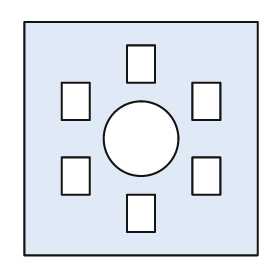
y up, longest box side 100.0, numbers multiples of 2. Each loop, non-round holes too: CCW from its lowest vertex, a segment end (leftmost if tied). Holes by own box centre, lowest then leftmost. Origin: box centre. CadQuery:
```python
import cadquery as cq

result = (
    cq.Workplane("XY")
    .moveTo(-50.0, -50.0)
    .lineTo(50.0, -50.0)
    .lineTo(50.0, 50.0)
    .lineTo(-50.0, 50.0)
    .close()
    .moveTo(-6.0, -40.0)
    .lineTo(6.0, -40.0)
    .lineTo(6.0, -24.0)
    .lineTo(-6.0, -24.0)
    .close()
    .moveTo(-34.0, -24.0)
    .lineTo(-22.0, -24.0)
    .lineTo(-22.0, -8.0)
    .lineTo(-34.0, -8.0)
    .close()
    .moveTo(22.0, -24.0)
    .lineTo(34.0, -24.0)
    .lineTo(34.0, -8.0)
    .lineTo(22.0, -8.0)
    .close()
    .moveTo(0.0, 0.0)
    .circle(16.0)
    .moveTo(-34.0, 8.0)
    .lineTo(-22.0, 8.0)
    .lineTo(-22.0, 24.0)
    .lineTo(-34.0, 24.0)
    .close()
    .moveTo(22.0, 8.0)
    .lineTo(34.0, 8.0)
    .lineTo(34.0, 24.0)
    .lineTo(22.0, 24.0)
    .close()
    .moveTo(-6.0, 24.0)
    .lineTo(6.0, 24.0)
    .lineTo(6.0, 40.0)
    .lineTo(-6.0, 40.0)
    .close()
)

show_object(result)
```